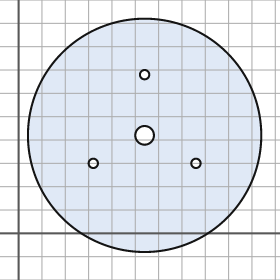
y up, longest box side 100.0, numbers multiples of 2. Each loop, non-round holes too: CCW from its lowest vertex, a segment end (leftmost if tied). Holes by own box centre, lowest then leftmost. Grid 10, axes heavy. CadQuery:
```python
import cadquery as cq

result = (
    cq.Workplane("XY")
    .moveTo(54.0, 42.0)
    .circle(50.0)
    .moveTo(32.0, 30.0)
    .circle(2.0)
    .moveTo(76.0, 30.0)
    .circle(2.0)
    .moveTo(54.0, 42.0)
    .circle(4.0)
    .moveTo(54.0, 68.0)
    .circle(2.0)
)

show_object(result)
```